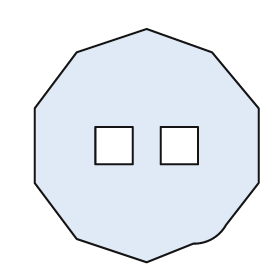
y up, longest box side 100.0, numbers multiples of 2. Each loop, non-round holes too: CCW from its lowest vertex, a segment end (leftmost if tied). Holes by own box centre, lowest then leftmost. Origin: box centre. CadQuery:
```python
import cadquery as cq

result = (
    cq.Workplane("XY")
    .moveTo(0.0, -50.0)
    .lineTo(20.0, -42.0)
    .threePointArc((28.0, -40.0), (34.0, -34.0))
    .lineTo(48.0, -16.0)
    .lineTo(48.0, 16.0)
    .lineTo(28.0, 40.0)
    .lineTo(0.0, 50.0)
    .lineTo(-30.0, 40.0)
    .lineTo(-48.0, 16.0)
    .lineTo(-48.0, -16.0)
    .lineTo(-30.0, -40.0)
    .close()
    .moveTo(-22.0, -8.0)
    .lineTo(-6.0, -8.0)
    .lineTo(-6.0, 8.0)
    .lineTo(-22.0, 8.0)
    .close()
    .moveTo(6.0, -8.0)
    .lineTo(22.0, -8.0)
    .lineTo(22.0, 8.0)
    .lineTo(6.0, 8.0)
    .close()
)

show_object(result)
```